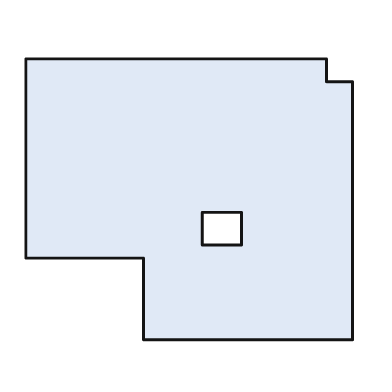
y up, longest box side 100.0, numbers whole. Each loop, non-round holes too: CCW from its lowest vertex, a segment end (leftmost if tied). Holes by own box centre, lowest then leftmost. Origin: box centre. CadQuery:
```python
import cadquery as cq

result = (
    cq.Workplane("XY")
    .moveTo(-14.0, -43.0)
    .lineTo(50.0, -43.0)
    .lineTo(50.0, 36.0)
    .lineTo(42.0, 36.0)
    .lineTo(42.0, 43.0)
    .lineTo(-50.0, 43.0)
    .lineTo(-50.0, -18.0)
    .lineTo(-14.0, -18.0)
    .close()
    .moveTo(4.0, -14.0)
    .lineTo(16.0, -14.0)
    .lineTo(16.0, -4.0)
    .lineTo(4.0, -4.0)
    .close()
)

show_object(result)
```